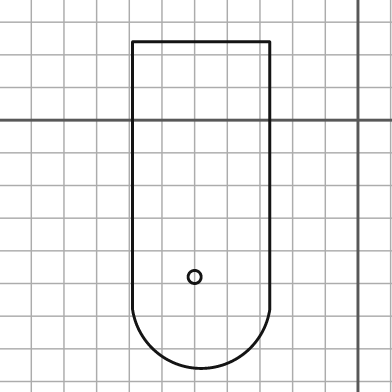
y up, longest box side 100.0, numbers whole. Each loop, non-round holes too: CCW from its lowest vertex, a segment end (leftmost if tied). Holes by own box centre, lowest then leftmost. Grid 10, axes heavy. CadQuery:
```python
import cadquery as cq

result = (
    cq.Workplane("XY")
    .moveTo(-69.0, -58.0)
    .threePointArc((-48.0, -76.0), (-27.0, -58.0))
    .lineTo(-27.0, 24.0)
    .lineTo(-69.0, 24.0)
    .close()
    .moveTo(-50.0, -48.0)
    .circle(2.0)
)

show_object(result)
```